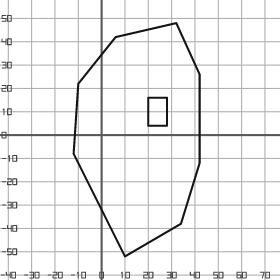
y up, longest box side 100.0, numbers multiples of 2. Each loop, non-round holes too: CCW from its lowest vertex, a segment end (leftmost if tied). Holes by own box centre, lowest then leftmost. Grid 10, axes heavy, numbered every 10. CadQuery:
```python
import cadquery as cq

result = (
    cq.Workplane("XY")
    .moveTo(10.0, -52.0)
    .lineTo(34.0, -38.0)
    .lineTo(42.0, -12.0)
    .lineTo(42.0, 26.0)
    .lineTo(32.0, 48.0)
    .lineTo(6.0, 42.0)
    .lineTo(-10.0, 22.0)
    .lineTo(-12.0, -8.0)
    .close()
    .moveTo(20.0, 4.0)
    .lineTo(28.0, 4.0)
    .lineTo(28.0, 16.0)
    .lineTo(20.0, 16.0)
    .close()
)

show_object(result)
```